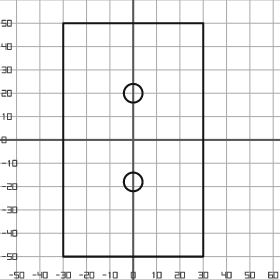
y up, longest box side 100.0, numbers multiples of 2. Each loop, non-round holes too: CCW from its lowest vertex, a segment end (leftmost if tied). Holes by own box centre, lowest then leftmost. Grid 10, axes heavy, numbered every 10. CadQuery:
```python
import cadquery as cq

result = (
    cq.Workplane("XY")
    .moveTo(-30.0, -50.0)
    .lineTo(30.0, -50.0)
    .lineTo(30.0, 50.0)
    .lineTo(-30.0, 50.0)
    .close()
    .moveTo(0.0, -18.0)
    .circle(4.0)
    .moveTo(0.0, 20.0)
    .circle(4.0)
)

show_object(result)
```